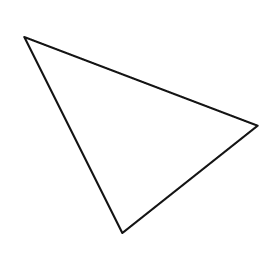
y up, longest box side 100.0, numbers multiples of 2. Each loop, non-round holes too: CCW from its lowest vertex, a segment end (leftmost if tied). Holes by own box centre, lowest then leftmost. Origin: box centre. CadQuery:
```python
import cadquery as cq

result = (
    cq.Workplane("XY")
    .moveTo(-8.0, -42.0)
    .lineTo(50.0, 4.0)
    .lineTo(-50.0, 42.0)
    .close()
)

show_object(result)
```